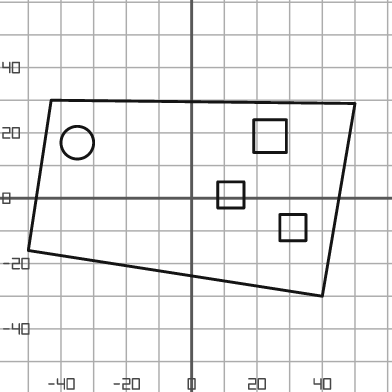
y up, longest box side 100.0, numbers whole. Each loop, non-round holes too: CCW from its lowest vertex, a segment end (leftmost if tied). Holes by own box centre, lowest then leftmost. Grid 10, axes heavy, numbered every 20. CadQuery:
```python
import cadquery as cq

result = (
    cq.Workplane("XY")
    .moveTo(40.0, -30.0)
    .lineTo(50.0, 29.0)
    .lineTo(-43.0, 30.0)
    .lineTo(-50.0, -16.0)
    .close()
    .moveTo(27.0, -13.0)
    .lineTo(35.0, -13.0)
    .lineTo(35.0, -5.0)
    .lineTo(27.0, -5.0)
    .close()
    .moveTo(8.0, -3.0)
    .lineTo(16.0, -3.0)
    .lineTo(16.0, 5.0)
    .lineTo(8.0, 5.0)
    .close()
    .moveTo(-35.0, 17.0)
    .circle(5.0)
    .moveTo(19.0, 14.0)
    .lineTo(29.0, 14.0)
    .lineTo(29.0, 24.0)
    .lineTo(19.0, 24.0)
    .close()
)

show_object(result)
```